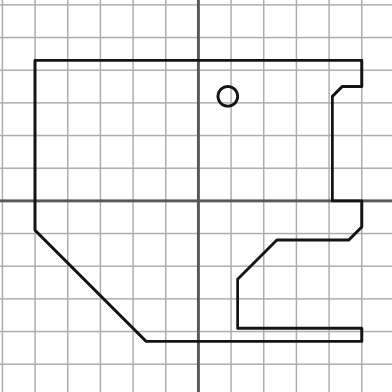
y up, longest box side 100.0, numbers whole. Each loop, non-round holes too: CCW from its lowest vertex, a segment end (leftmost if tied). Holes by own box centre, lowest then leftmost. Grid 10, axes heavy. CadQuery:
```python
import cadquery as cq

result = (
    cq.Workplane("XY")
    .moveTo(-16.0, -43.0)
    .lineTo(50.0, -43.0)
    .lineTo(50.0, -39.0)
    .lineTo(12.0, -39.0)
    .lineTo(12.0, -24.0)
    .lineTo(24.0, -12.0)
    .lineTo(46.0, -12.0)
    .lineTo(50.0, -8.0)
    .lineTo(50.0, 0.0)
    .lineTo(41.0, 0.0)
    .lineTo(41.0, 32.0)
    .lineTo(44.0, 35.0)
    .lineTo(50.0, 35.0)
    .lineTo(50.0, 43.0)
    .lineTo(-50.0, 43.0)
    .lineTo(-50.0, -9.0)
    .close()
    .moveTo(9.0, 32.0)
    .circle(3.0)
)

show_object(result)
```